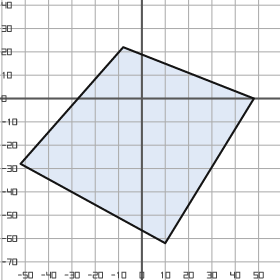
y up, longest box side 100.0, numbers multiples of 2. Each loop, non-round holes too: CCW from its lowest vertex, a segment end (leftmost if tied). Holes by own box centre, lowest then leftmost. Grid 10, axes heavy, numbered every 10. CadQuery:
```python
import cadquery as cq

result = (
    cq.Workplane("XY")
    .moveTo(10.0, -62.0)
    .lineTo(48.0, 0.0)
    .lineTo(-8.0, 22.0)
    .lineTo(-52.0, -28.0)
    .close()
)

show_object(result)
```